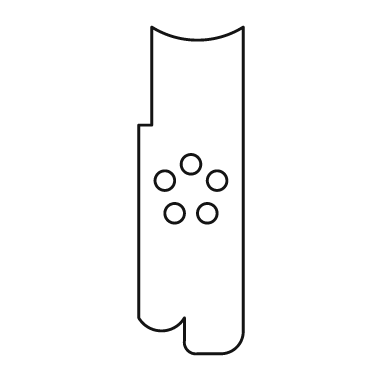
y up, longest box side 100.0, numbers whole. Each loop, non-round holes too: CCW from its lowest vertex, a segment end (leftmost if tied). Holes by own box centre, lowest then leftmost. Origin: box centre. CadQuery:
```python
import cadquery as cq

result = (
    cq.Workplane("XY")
    .moveTo(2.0, -50.0)
    .lineTo(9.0, -50.0)
    .threePointArc((14.0, -48.0), (16.0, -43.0))
    .lineTo(16.0, 50.0)
    .threePointArc((2.0, 46.0), (-12.0, 50.0))
    .lineTo(-12.0, 20.0)
    .lineTo(-16.0, 20.0)
    .lineTo(-16.0, -39.0)
    .threePointArc((-9.0, -43.0), (-2.0, -39.0))
    .lineTo(-2.0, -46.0)
    .threePointArc((-1.0, -49.0), (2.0, -50.0))
    .close()
    .moveTo(-5.0, -7.0)
    .circle(3.0)
    .moveTo(5.0, -7.0)
    .circle(3.0)
    .moveTo(-8.0, 3.0)
    .circle(3.0)
    .moveTo(8.0, 3.0)
    .circle(3.0)
    .moveTo(0.0, 8.0)
    .circle(3.0)
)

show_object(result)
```